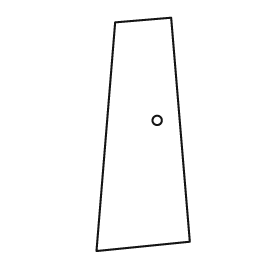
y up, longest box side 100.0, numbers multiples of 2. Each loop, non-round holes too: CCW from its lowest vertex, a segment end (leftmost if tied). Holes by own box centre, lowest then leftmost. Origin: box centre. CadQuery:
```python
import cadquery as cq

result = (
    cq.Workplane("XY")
    .moveTo(-20.0, -50.0)
    .lineTo(20.0, -46.0)
    .lineTo(12.0, 50.0)
    .lineTo(-12.0, 48.0)
    .close()
    .moveTo(6.0, 6.0)
    .circle(2.0)
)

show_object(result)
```